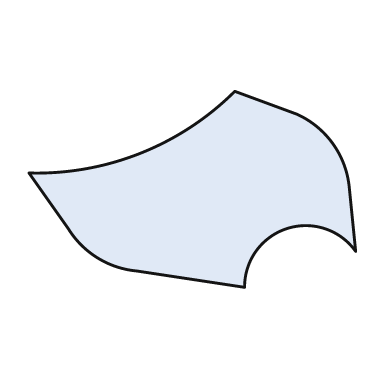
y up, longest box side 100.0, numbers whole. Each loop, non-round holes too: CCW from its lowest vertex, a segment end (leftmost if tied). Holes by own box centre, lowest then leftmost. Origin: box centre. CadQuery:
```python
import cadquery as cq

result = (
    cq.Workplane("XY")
    .moveTo(16.0, -30.0)
    .threePointArc((29.0, -12.0), (50.0, -19.0))
    .lineTo(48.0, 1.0)
    .threePointArc((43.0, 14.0), (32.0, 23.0))
    .lineTo(13.0, 30.0)
    .threePointArc((-16.0, 11.0), (-50.0, 5.0))
    .lineTo(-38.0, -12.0)
    .threePointArc((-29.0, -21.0), (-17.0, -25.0))
    .close()
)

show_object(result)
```